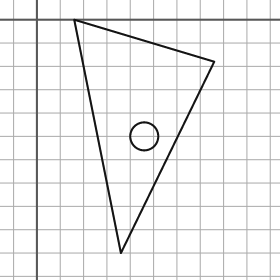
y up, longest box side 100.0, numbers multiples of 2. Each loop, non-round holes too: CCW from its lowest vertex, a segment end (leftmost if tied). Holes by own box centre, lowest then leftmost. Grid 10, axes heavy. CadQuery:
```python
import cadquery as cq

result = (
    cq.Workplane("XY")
    .moveTo(36.0, -100.0)
    .lineTo(76.0, -18.0)
    .lineTo(16.0, 0.0)
    .close()
    .moveTo(46.0, -50.0)
    .circle(6.0)
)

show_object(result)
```